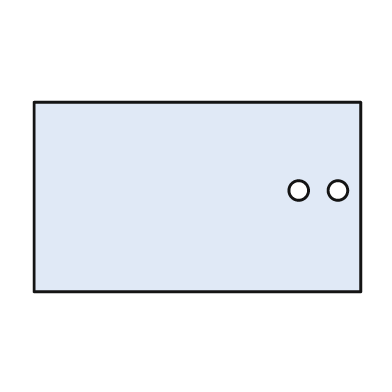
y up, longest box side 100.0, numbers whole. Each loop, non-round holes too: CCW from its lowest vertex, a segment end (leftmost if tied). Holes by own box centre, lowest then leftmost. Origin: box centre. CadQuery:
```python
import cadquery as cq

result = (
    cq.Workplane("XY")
    .moveTo(-50.0, -29.0)
    .lineTo(50.0, -29.0)
    .lineTo(50.0, 29.0)
    .lineTo(-50.0, 29.0)
    .close()
    .moveTo(31.0, 2.0)
    .circle(3.0)
    .moveTo(43.0, 2.0)
    .circle(3.0)
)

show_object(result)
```